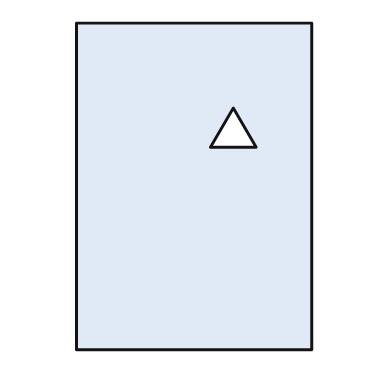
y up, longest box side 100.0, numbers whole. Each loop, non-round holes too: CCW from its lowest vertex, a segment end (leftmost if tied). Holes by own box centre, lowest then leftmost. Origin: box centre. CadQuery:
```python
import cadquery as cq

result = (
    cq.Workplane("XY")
    .moveTo(-36.0, -50.0)
    .lineTo(36.0, -50.0)
    .lineTo(36.0, 50.0)
    .lineTo(-36.0, 50.0)
    .close()
    .moveTo(5.0, 12.0)
    .lineTo(19.0, 12.0)
    .lineTo(12.0, 24.0)
    .close()
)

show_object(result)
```